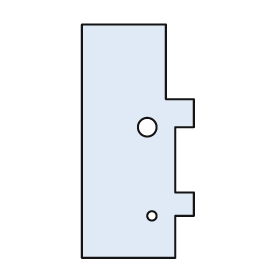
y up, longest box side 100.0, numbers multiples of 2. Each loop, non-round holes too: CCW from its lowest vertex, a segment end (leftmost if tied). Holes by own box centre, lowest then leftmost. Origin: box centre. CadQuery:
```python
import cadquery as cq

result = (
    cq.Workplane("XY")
    .moveTo(-24.0, -50.0)
    .lineTo(16.0, -50.0)
    .lineTo(16.0, -32.0)
    .lineTo(24.0, -32.0)
    .lineTo(24.0, -22.0)
    .lineTo(16.0, -22.0)
    .lineTo(16.0, 6.0)
    .lineTo(24.0, 6.0)
    .lineTo(24.0, 18.0)
    .lineTo(12.0, 18.0)
    .lineTo(12.0, 50.0)
    .lineTo(-24.0, 50.0)
    .close()
    .moveTo(6.0, -32.0)
    .circle(2.0)
    .moveTo(4.0, 6.0)
    .circle(4.0)
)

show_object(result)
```